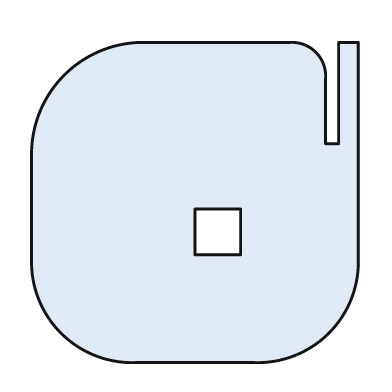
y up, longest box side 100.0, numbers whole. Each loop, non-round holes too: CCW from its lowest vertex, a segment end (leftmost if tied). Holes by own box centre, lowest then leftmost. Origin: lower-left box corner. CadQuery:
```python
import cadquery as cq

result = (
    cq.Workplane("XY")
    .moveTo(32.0, 0.0)
    .lineTo(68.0, 0.0)
    .threePointArc((91.0, 9.0), (100.0, 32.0))
    .lineTo(100.0, 98.0)
    .lineTo(94.0, 98.0)
    .lineTo(94.0, 67.0)
    .lineTo(90.0, 67.0)
    .lineTo(90.0, 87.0)
    .threePointArc((87.0, 95.0), (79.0, 98.0))
    .lineTo(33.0, 98.0)
    .threePointArc((10.0, 88.0), (0.0, 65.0))
    .lineTo(0.0, 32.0)
    .threePointArc((9.0, 9.0), (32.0, 0.0))
    .close()
    .moveTo(50.0, 33.0)
    .lineTo(64.0, 33.0)
    .lineTo(64.0, 47.0)
    .lineTo(50.0, 47.0)
    .close()
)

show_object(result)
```